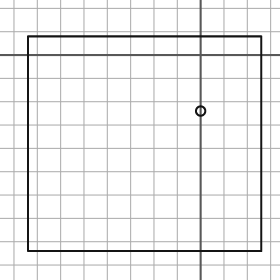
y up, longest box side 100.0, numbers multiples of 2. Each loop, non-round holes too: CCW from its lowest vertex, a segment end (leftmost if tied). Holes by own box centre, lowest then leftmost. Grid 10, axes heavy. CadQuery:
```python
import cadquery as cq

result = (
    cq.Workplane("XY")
    .moveTo(-74.0, -84.0)
    .lineTo(26.0, -84.0)
    .lineTo(26.0, 8.0)
    .lineTo(-74.0, 8.0)
    .close()
    .moveTo(0.0, -24.0)
    .circle(2.0)
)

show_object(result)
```